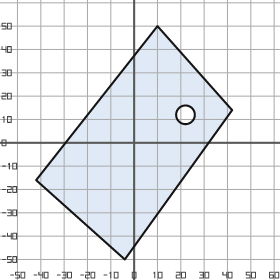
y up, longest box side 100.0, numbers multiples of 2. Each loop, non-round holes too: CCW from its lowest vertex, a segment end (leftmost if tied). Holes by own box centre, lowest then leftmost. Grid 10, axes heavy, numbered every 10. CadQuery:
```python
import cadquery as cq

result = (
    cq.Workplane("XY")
    .moveTo(-4.0, -50.0)
    .lineTo(42.0, 14.0)
    .lineTo(10.0, 50.0)
    .lineTo(-42.0, -16.0)
    .close()
    .moveTo(22.0, 12.0)
    .circle(4.0)
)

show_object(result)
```